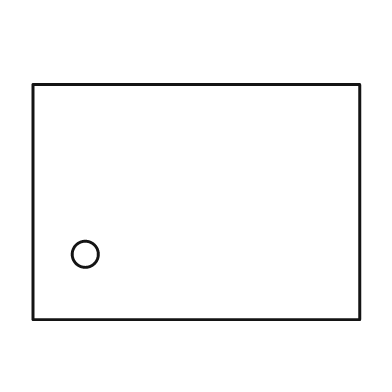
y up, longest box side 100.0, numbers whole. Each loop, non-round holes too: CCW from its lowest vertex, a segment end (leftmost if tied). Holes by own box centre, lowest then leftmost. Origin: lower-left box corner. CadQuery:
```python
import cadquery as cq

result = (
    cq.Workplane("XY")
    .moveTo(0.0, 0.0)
    .lineTo(100.0, 0.0)
    .lineTo(100.0, 72.0)
    .lineTo(0.0, 72.0)
    .close()
    .moveTo(16.0, 20.0)
    .circle(4.0)
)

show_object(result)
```